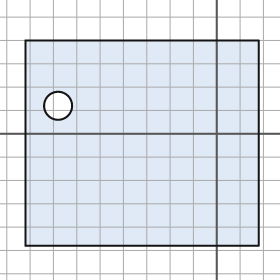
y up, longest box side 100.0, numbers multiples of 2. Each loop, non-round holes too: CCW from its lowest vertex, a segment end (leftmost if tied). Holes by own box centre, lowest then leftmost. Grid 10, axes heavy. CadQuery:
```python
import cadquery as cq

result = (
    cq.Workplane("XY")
    .moveTo(-82.0, -48.0)
    .lineTo(18.0, -48.0)
    .lineTo(18.0, 40.0)
    .lineTo(-82.0, 40.0)
    .close()
    .moveTo(-68.0, 12.0)
    .circle(6.0)
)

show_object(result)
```